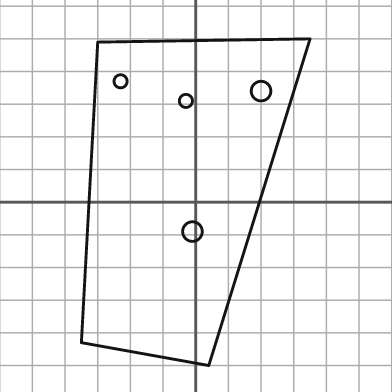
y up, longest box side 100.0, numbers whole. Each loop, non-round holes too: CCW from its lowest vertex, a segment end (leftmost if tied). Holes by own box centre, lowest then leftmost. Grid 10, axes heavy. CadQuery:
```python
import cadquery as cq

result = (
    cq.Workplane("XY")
    .moveTo(4.0, -50.0)
    .lineTo(35.0, 50.0)
    .lineTo(-30.0, 49.0)
    .lineTo(-35.0, -43.0)
    .close()
    .moveTo(-1.0, -9.0)
    .circle(3.0)
    .moveTo(-3.0, 31.0)
    .circle(2.0)
    .moveTo(20.0, 34.0)
    .circle(3.0)
    .moveTo(-23.0, 37.0)
    .circle(2.0)
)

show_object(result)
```